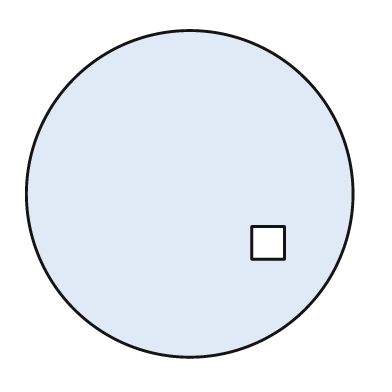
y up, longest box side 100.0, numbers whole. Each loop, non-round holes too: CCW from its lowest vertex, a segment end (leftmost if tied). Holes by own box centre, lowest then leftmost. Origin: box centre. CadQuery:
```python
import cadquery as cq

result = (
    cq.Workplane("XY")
    .moveTo(0.0, 0.0)
    .circle(50.0)
    .moveTo(19.0, -20.0)
    .lineTo(29.0, -20.0)
    .lineTo(29.0, -10.0)
    .lineTo(19.0, -10.0)
    .close()
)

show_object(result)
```